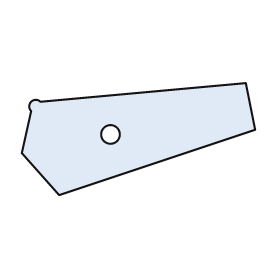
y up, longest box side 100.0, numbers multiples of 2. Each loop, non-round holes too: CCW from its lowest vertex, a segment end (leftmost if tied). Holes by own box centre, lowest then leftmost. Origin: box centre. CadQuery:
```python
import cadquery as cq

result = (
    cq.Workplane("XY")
    .moveTo(-34.0, -24.0)
    .lineTo(50.0, 4.0)
    .lineTo(46.0, 24.0)
    .lineTo(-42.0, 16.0)
    .threePointArc((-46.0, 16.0), (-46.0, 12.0))
    .lineTo(-50.0, -6.0)
    .close()
    .moveTo(-12.0, 2.0)
    .circle(4.0)
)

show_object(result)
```